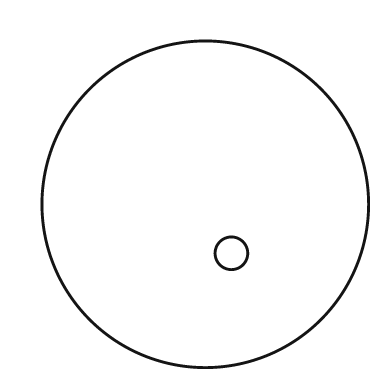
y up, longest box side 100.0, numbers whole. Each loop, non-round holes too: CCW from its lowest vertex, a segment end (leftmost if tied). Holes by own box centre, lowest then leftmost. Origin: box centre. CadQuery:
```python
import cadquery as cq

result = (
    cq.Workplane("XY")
    .moveTo(0.0, 0.0)
    .circle(50.0)
    .moveTo(8.0, -15.0)
    .circle(5.0)
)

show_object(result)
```